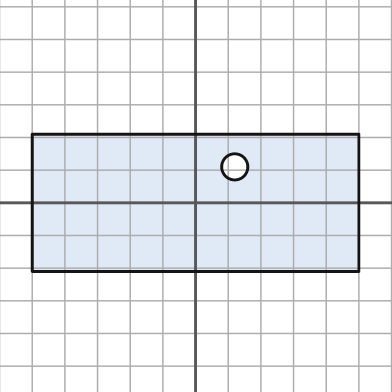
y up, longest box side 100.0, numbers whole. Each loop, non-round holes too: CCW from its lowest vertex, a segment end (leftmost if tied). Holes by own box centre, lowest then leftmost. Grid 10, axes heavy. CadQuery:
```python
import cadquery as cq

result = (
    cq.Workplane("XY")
    .moveTo(-50.0, -21.0)
    .lineTo(50.0, -21.0)
    .lineTo(50.0, 21.0)
    .lineTo(-50.0, 21.0)
    .close()
    .moveTo(12.0, 11.0)
    .circle(4.0)
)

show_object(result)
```